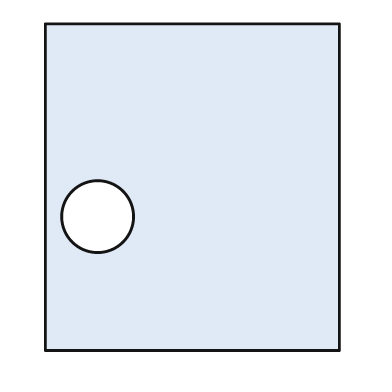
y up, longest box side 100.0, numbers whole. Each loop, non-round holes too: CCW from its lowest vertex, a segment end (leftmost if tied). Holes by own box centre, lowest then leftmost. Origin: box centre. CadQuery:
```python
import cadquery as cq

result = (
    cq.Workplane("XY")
    .moveTo(-45.0, -50.0)
    .lineTo(45.0, -50.0)
    .lineTo(45.0, 50.0)
    .lineTo(-45.0, 50.0)
    .close()
    .moveTo(-29.0, -9.0)
    .circle(11.0)
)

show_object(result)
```